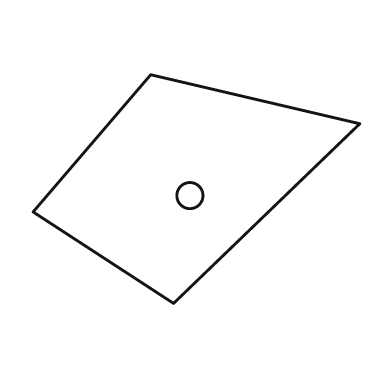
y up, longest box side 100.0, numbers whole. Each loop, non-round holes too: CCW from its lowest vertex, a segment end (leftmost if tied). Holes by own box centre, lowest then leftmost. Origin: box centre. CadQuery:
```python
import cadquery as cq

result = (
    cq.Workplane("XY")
    .moveTo(-7.0, -35.0)
    .lineTo(50.0, 20.0)
    .lineTo(-14.0, 35.0)
    .lineTo(-50.0, -7.0)
    .close()
    .moveTo(-2.0, -2.0)
    .circle(4.0)
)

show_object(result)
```